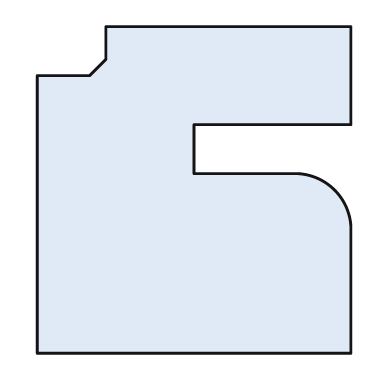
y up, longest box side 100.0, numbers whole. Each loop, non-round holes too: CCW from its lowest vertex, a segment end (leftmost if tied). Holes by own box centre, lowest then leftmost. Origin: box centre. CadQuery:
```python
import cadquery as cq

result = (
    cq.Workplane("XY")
    .moveTo(-48.0, -50.0)
    .lineTo(48.0, -50.0)
    .lineTo(48.0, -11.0)
    .threePointArc((43.0, 0.0), (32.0, 5.0))
    .lineTo(0.0, 5.0)
    .lineTo(0.0, 20.0)
    .lineTo(48.0, 20.0)
    .lineTo(48.0, 50.0)
    .lineTo(-27.0, 50.0)
    .lineTo(-27.0, 40.0)
    .lineTo(-32.0, 35.0)
    .lineTo(-48.0, 35.0)
    .close()
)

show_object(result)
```